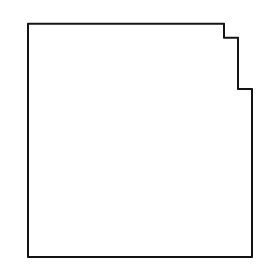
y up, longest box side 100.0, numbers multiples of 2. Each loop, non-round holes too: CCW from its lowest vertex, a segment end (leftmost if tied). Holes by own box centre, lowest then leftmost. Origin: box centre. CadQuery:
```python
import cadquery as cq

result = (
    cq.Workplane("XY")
    .moveTo(-48.0, -50.0)
    .lineTo(48.0, -50.0)
    .lineTo(48.0, 22.0)
    .lineTo(42.0, 22.0)
    .lineTo(42.0, 44.0)
    .lineTo(36.0, 44.0)
    .lineTo(36.0, 50.0)
    .lineTo(-48.0, 50.0)
    .close()
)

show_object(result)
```